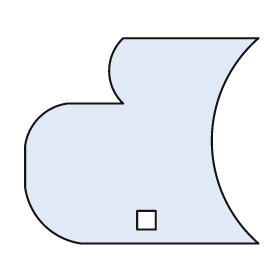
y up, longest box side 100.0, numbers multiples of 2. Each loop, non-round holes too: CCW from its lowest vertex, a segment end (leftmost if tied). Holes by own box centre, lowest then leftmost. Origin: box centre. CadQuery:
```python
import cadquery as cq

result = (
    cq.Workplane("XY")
    .moveTo(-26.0, -44.0)
    .lineTo(50.0, -44.0)
    .threePointArc((30.0, 0.0), (50.0, 44.0))
    .lineTo(-8.0, 44.0)
    .threePointArc((-14.0, 30.0), (-8.0, 16.0))
    .lineTo(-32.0, 16.0)
    .threePointArc((-44.0, 10.0), (-50.0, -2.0))
    .lineTo(-50.0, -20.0)
    .threePointArc((-42.0, -36.0), (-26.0, -44.0))
    .close()
    .moveTo(-2.0, -38.0)
    .lineTo(6.0, -38.0)
    .lineTo(6.0, -30.0)
    .lineTo(-2.0, -30.0)
    .close()
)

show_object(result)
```